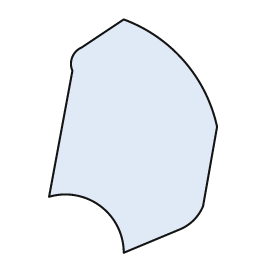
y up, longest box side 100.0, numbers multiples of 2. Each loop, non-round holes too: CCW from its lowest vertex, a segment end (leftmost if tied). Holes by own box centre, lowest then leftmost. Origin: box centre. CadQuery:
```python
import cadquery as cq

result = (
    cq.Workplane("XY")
    .moveTo(-4.0, -50.0)
    .lineTo(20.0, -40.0)
    .threePointArc((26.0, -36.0), (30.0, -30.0))
    .lineTo(36.0, 4.0)
    .threePointArc((22.0, 32.0), (-4.0, 50.0))
    .lineTo(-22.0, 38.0)
    .threePointArc((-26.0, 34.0), (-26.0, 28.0))
    .lineTo(-36.0, -26.0)
    .threePointArc((-14.0, -30.0), (-4.0, -50.0))
    .close()
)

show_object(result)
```